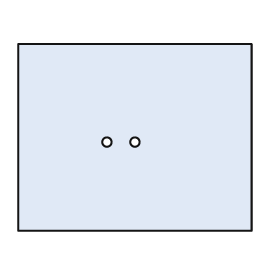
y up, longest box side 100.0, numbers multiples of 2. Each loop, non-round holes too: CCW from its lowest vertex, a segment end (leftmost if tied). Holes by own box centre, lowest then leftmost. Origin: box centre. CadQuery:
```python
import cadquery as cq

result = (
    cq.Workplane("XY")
    .moveTo(-50.0, -40.0)
    .lineTo(50.0, -40.0)
    .lineTo(50.0, 40.0)
    .lineTo(-50.0, 40.0)
    .close()
    .moveTo(-12.0, -2.0)
    .circle(2.0)
    .moveTo(0.0, -2.0)
    .circle(2.0)
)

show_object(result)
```